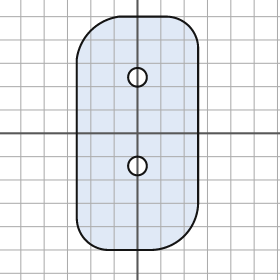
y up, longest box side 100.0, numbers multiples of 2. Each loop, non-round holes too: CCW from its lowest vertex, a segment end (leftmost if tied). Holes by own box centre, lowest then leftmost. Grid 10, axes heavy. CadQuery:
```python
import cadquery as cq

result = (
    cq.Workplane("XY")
    .moveTo(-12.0, -50.0)
    .lineTo(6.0, -50.0)
    .threePointArc((20.0, -44.0), (26.0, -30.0))
    .lineTo(26.0, 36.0)
    .threePointArc((22.0, 46.0), (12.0, 50.0))
    .lineTo(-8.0, 50.0)
    .threePointArc((-20.0, 44.0), (-26.0, 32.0))
    .lineTo(-26.0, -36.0)
    .threePointArc((-22.0, -46.0), (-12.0, -50.0))
    .close()
    .moveTo(0.0, -14.0)
    .circle(4.0)
    .moveTo(0.0, 24.0)
    .circle(4.0)
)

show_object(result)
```